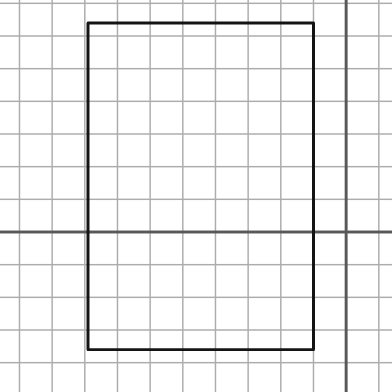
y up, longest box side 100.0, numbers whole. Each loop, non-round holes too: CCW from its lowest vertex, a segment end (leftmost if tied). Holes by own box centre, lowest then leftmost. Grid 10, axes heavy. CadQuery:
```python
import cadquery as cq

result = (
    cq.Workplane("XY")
    .moveTo(-79.0, -36.0)
    .lineTo(-10.0, -36.0)
    .lineTo(-10.0, 64.0)
    .lineTo(-79.0, 64.0)
    .close()
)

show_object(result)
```